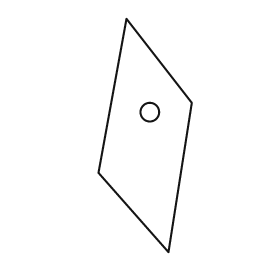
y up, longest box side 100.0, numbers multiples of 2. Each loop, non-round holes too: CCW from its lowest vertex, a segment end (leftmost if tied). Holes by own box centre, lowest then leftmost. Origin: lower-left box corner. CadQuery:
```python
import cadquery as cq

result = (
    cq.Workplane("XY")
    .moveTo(30.0, 0.0)
    .lineTo(40.0, 64.0)
    .lineTo(12.0, 100.0)
    .lineTo(0.0, 34.0)
    .close()
    .moveTo(22.0, 60.0)
    .circle(4.0)
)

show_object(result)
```